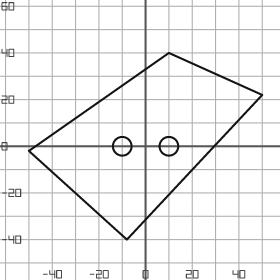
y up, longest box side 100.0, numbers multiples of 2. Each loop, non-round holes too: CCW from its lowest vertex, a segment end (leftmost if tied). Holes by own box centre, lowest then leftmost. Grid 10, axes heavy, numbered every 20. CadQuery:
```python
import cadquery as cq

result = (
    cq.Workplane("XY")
    .moveTo(-8.0, -40.0)
    .lineTo(50.0, 22.0)
    .lineTo(10.0, 40.0)
    .lineTo(-50.0, -2.0)
    .close()
    .moveTo(-10.0, 0.0)
    .circle(4.0)
    .moveTo(10.0, 0.0)
    .circle(4.0)
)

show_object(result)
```